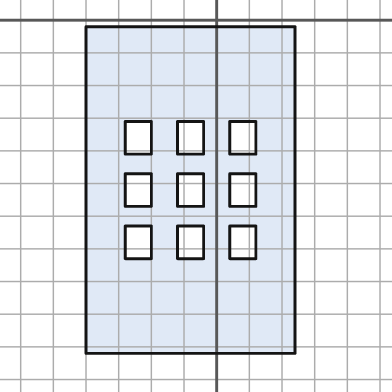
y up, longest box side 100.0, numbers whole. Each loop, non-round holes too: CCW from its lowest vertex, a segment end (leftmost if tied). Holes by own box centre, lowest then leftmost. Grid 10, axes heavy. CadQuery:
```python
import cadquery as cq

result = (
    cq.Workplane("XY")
    .moveTo(-40.0, -102.0)
    .lineTo(24.0, -102.0)
    .lineTo(24.0, -2.0)
    .lineTo(-40.0, -2.0)
    .close()
    .moveTo(-28.0, -73.0)
    .lineTo(-20.0, -73.0)
    .lineTo(-20.0, -63.0)
    .lineTo(-28.0, -63.0)
    .close()
    .moveTo(-12.0, -73.0)
    .lineTo(-4.0, -73.0)
    .lineTo(-4.0, -63.0)
    .lineTo(-12.0, -63.0)
    .close()
    .moveTo(4.0, -73.0)
    .lineTo(12.0, -73.0)
    .lineTo(12.0, -63.0)
    .lineTo(4.0, -63.0)
    .close()
    .moveTo(-28.0, -57.0)
    .lineTo(-20.0, -57.0)
    .lineTo(-20.0, -47.0)
    .lineTo(-28.0, -47.0)
    .close()
    .moveTo(-12.0, -57.0)
    .lineTo(-4.0, -57.0)
    .lineTo(-4.0, -47.0)
    .lineTo(-12.0, -47.0)
    .close()
    .moveTo(4.0, -57.0)
    .lineTo(12.0, -57.0)
    .lineTo(12.0, -47.0)
    .lineTo(4.0, -47.0)
    .close()
    .moveTo(-28.0, -41.0)
    .lineTo(-20.0, -41.0)
    .lineTo(-20.0, -31.0)
    .lineTo(-28.0, -31.0)
    .close()
    .moveTo(-12.0, -41.0)
    .lineTo(-4.0, -41.0)
    .lineTo(-4.0, -31.0)
    .lineTo(-12.0, -31.0)
    .close()
    .moveTo(4.0, -41.0)
    .lineTo(12.0, -41.0)
    .lineTo(12.0, -31.0)
    .lineTo(4.0, -31.0)
    .close()
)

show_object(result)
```